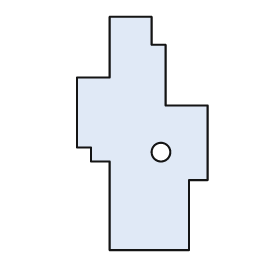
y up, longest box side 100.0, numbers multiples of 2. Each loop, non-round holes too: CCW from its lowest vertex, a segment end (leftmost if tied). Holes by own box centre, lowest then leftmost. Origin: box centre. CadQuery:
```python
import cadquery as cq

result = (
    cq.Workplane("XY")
    .moveTo(-14.0, -50.0)
    .lineTo(20.0, -50.0)
    .lineTo(20.0, -20.0)
    .lineTo(28.0, -20.0)
    .lineTo(28.0, 12.0)
    .lineTo(10.0, 12.0)
    .lineTo(10.0, 38.0)
    .lineTo(4.0, 38.0)
    .lineTo(4.0, 50.0)
    .lineTo(-14.0, 50.0)
    .lineTo(-14.0, 24.0)
    .lineTo(-28.0, 24.0)
    .lineTo(-28.0, -6.0)
    .lineTo(-22.0, -6.0)
    .lineTo(-22.0, -12.0)
    .lineTo(-14.0, -12.0)
    .close()
    .moveTo(8.0, -8.0)
    .circle(4.0)
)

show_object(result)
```